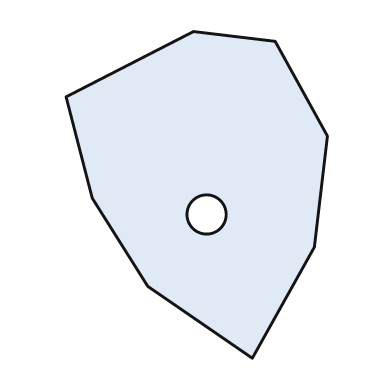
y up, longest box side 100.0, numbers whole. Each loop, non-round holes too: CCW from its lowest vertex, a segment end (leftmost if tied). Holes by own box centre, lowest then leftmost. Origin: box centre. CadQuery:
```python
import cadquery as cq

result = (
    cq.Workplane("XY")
    .moveTo(17.0, -50.0)
    .lineTo(36.0, -16.0)
    .lineTo(40.0, 18.0)
    .lineTo(24.0, 47.0)
    .lineTo(-1.0, 50.0)
    .lineTo(-40.0, 30.0)
    .lineTo(-32.0, -1.0)
    .lineTo(-15.0, -28.0)
    .close()
    .moveTo(3.0, -6.0)
    .circle(6.0)
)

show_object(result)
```